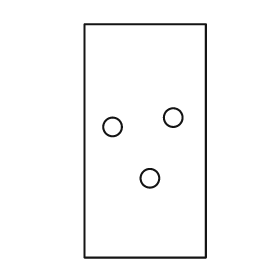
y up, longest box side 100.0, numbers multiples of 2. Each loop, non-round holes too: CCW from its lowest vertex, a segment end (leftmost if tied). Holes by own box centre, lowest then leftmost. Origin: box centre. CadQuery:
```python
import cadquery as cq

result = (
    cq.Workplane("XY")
    .moveTo(-26.0, -50.0)
    .lineTo(26.0, -50.0)
    .lineTo(26.0, 50.0)
    .lineTo(-26.0, 50.0)
    .close()
    .moveTo(2.0, -16.0)
    .circle(4.0)
    .moveTo(-14.0, 6.0)
    .circle(4.0)
    .moveTo(12.0, 10.0)
    .circle(4.0)
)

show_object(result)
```